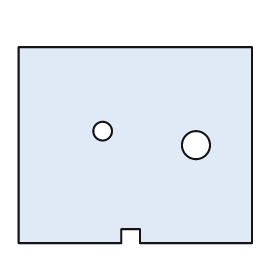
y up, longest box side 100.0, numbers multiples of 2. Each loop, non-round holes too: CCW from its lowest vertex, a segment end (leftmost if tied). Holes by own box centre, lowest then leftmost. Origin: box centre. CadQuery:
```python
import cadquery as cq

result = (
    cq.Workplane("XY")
    .moveTo(-50.0, -42.0)
    .lineTo(-6.0, -42.0)
    .lineTo(-6.0, -36.0)
    .lineTo(2.0, -36.0)
    .lineTo(2.0, -42.0)
    .lineTo(50.0, -42.0)
    .lineTo(50.0, 42.0)
    .lineTo(-50.0, 42.0)
    .close()
    .moveTo(26.0, 0.0)
    .circle(6.0)
    .moveTo(-14.0, 6.0)
    .circle(4.0)
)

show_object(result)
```